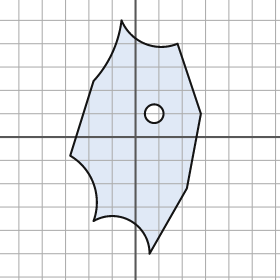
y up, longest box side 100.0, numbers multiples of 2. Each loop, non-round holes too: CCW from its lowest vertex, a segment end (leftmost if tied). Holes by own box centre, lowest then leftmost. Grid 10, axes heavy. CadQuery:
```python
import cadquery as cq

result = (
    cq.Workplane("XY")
    .moveTo(6.0, -50.0)
    .lineTo(22.0, -22.0)
    .lineTo(28.0, 10.0)
    .lineTo(18.0, 40.0)
    .threePointArc((4.0, 40.0), (-6.0, 50.0))
    .threePointArc((-10.0, 36.0), (-18.0, 24.0))
    .lineTo(-28.0, -8.0)
    .threePointArc((-18.0, -20.0), (-18.0, -36.0))
    .threePointArc((-2.0, -36.0), (6.0, -50.0))
    .close()
    .moveTo(8.0, 10.0)
    .circle(4.0)
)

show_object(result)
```